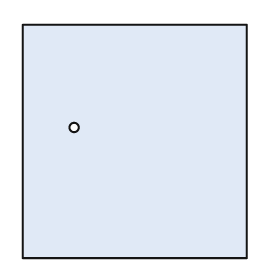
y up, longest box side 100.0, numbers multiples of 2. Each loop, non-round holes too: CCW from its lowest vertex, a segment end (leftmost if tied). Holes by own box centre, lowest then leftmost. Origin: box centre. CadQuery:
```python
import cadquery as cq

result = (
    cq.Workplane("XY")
    .moveTo(-48.0, -50.0)
    .lineTo(48.0, -50.0)
    .lineTo(48.0, 50.0)
    .lineTo(-48.0, 50.0)
    .close()
    .moveTo(-26.0, 6.0)
    .circle(2.0)
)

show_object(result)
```